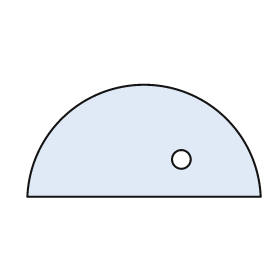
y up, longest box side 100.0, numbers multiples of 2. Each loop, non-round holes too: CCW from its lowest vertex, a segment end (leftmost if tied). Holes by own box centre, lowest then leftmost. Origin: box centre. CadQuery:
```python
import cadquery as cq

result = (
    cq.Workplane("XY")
    .moveTo(-50.0, -24.0)
    .lineTo(50.0, -24.0)
    .threePointArc((0.0, 24.0), (-50.0, -24.0))
    .close()
    .moveTo(16.0, -8.0)
    .circle(4.0)
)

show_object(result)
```